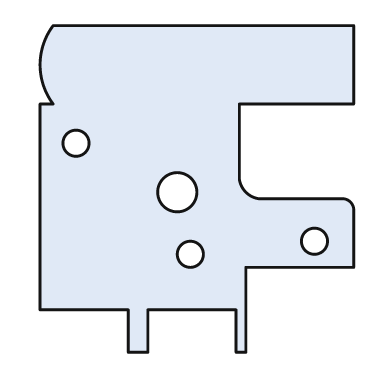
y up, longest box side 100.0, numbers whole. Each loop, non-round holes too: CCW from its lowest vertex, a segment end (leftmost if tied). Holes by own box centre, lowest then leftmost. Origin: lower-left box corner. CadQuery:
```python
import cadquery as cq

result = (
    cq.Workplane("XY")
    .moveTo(27.0, 0.0)
    .lineTo(33.0, 0.0)
    .lineTo(33.0, 13.0)
    .lineTo(60.0, 13.0)
    .lineTo(60.0, 0.0)
    .lineTo(63.0, 0.0)
    .lineTo(63.0, 26.0)
    .lineTo(96.0, 26.0)
    .lineTo(96.0, 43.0)
    .threePointArc((95.0, 46.0), (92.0, 47.0))
    .lineTo(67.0, 47.0)
    .threePointArc((63.0, 49.0), (61.0, 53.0))
    .lineTo(61.0, 76.0)
    .lineTo(96.0, 76.0)
    .lineTo(96.0, 100.0)
    .lineTo(4.0, 100.0)
    .threePointArc((0.0, 88.0), (4.0, 76.0))
    .lineTo(0.0, 76.0)
    .lineTo(0.0, 13.0)
    .lineTo(27.0, 13.0)
    .close()
    .moveTo(46.0, 30.0)
    .circle(4.0)
    .moveTo(84.0, 34.0)
    .circle(4.0)
    .moveTo(42.0, 49.0)
    .circle(6.0)
    .moveTo(11.0, 64.0)
    .circle(4.0)
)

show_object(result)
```